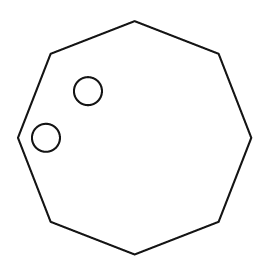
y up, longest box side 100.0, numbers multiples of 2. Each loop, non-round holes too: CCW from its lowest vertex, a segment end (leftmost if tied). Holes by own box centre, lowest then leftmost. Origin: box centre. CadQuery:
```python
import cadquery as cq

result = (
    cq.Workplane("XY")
    .moveTo(0.0, -50.0)
    .lineTo(36.0, -36.0)
    .lineTo(50.0, 0.0)
    .lineTo(36.0, 36.0)
    .lineTo(0.0, 50.0)
    .lineTo(-36.0, 36.0)
    .lineTo(-50.0, 0.0)
    .lineTo(-36.0, -36.0)
    .close()
    .moveTo(-38.0, 0.0)
    .circle(6.0)
    .moveTo(-20.0, 20.0)
    .circle(6.0)
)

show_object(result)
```